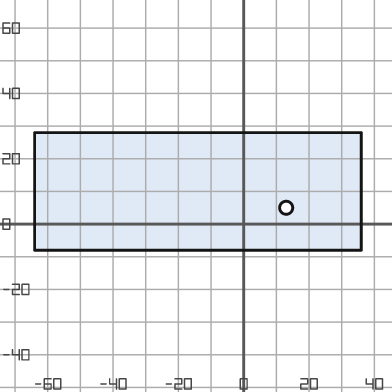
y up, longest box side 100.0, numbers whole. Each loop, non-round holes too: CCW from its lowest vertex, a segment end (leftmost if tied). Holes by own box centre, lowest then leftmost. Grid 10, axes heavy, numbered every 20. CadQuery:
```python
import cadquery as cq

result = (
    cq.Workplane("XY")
    .moveTo(-64.0, -8.0)
    .lineTo(36.0, -8.0)
    .lineTo(36.0, 28.0)
    .lineTo(-64.0, 28.0)
    .close()
    .moveTo(13.0, 5.0)
    .circle(2.0)
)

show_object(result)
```